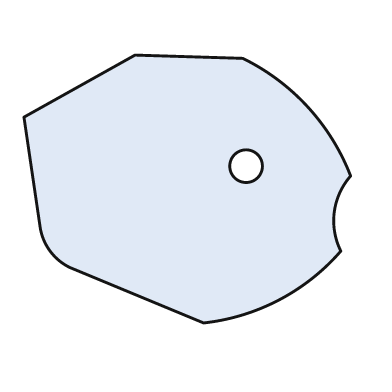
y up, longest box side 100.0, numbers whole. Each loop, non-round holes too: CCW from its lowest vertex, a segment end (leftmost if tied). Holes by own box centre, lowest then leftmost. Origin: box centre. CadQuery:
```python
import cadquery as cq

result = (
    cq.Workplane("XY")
    .moveTo(5.0, -41.0)
    .threePointArc((28.0, -34.0), (47.0, -19.0))
    .threePointArc((45.0, -7.0), (50.0, 4.0))
    .threePointArc((37.0, 25.0), (17.0, 40.0))
    .lineTo(-16.0, 41.0)
    .lineTo(-50.0, 22.0)
    .lineTo(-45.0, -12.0)
    .threePointArc((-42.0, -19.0), (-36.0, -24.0))
    .close()
    .moveTo(18.0, 7.0)
    .circle(5.0)
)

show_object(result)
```